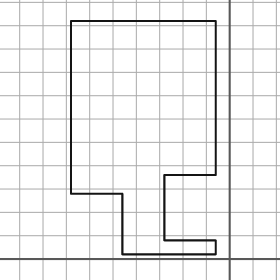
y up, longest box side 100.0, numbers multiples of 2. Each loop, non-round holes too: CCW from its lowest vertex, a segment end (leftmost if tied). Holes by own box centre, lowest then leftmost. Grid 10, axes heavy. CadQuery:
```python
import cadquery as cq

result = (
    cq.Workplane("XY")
    .moveTo(-46.0, 2.0)
    .lineTo(-6.0, 2.0)
    .lineTo(-6.0, 8.0)
    .lineTo(-28.0, 8.0)
    .lineTo(-28.0, 36.0)
    .lineTo(-6.0, 36.0)
    .lineTo(-6.0, 102.0)
    .lineTo(-68.0, 102.0)
    .lineTo(-68.0, 28.0)
    .lineTo(-46.0, 28.0)
    .close()
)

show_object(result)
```